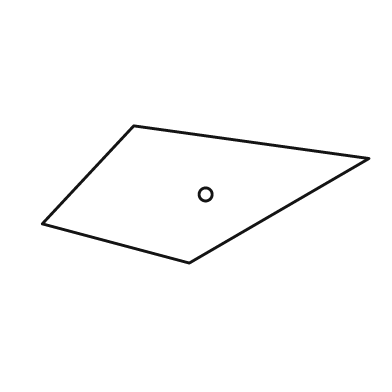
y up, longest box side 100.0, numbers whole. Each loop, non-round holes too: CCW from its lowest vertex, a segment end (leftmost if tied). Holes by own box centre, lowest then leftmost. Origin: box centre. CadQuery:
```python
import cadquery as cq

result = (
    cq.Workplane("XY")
    .moveTo(-5.0, -21.0)
    .lineTo(50.0, 11.0)
    .lineTo(-22.0, 21.0)
    .lineTo(-50.0, -9.0)
    .close()
    .moveTo(0.0, 0.0)
    .circle(2.0)
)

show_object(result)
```